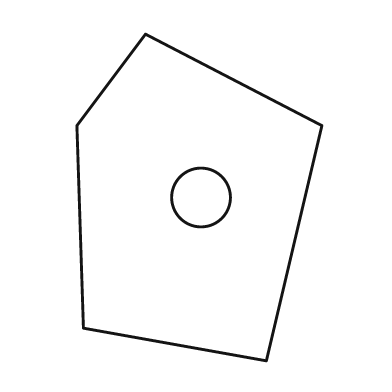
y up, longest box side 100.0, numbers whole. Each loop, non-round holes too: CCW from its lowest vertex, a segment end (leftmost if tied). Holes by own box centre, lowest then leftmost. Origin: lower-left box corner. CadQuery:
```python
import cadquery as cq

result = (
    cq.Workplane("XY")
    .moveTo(58.0, 0.0)
    .lineTo(75.0, 72.0)
    .lineTo(21.0, 100.0)
    .lineTo(0.0, 72.0)
    .lineTo(2.0, 10.0)
    .close()
    .moveTo(38.0, 50.0)
    .circle(9.0)
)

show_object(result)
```